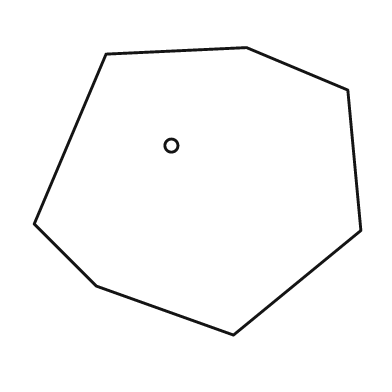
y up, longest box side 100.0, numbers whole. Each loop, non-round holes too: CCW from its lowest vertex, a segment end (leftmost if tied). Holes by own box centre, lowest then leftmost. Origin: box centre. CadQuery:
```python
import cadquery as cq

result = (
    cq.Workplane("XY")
    .moveTo(11.0, -44.0)
    .lineTo(50.0, -12.0)
    .lineTo(46.0, 31.0)
    .lineTo(15.0, 44.0)
    .lineTo(-28.0, 42.0)
    .lineTo(-50.0, -10.0)
    .lineTo(-31.0, -29.0)
    .close()
    .moveTo(-8.0, 14.0)
    .circle(2.0)
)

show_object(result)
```